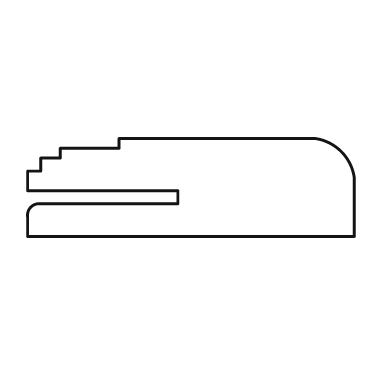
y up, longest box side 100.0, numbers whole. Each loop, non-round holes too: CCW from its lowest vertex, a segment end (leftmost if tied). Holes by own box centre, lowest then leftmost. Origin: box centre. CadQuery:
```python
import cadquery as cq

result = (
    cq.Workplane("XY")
    .moveTo(-50.0, -15.0)
    .lineTo(50.0, -15.0)
    .lineTo(50.0, 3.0)
    .threePointArc((46.0, 11.0), (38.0, 15.0))
    .lineTo(-22.0, 15.0)
    .lineTo(-22.0, 12.0)
    .lineTo(-40.0, 12.0)
    .lineTo(-40.0, 9.0)
    .lineTo(-46.0, 9.0)
    .lineTo(-46.0, 5.0)
    .lineTo(-50.0, 5.0)
    .lineTo(-50.0, -1.0)
    .lineTo(-4.0, -1.0)
    .lineTo(-4.0, -5.0)
    .lineTo(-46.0, -5.0)
    .threePointArc((-49.0, -6.0), (-50.0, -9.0))
    .close()
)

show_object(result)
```